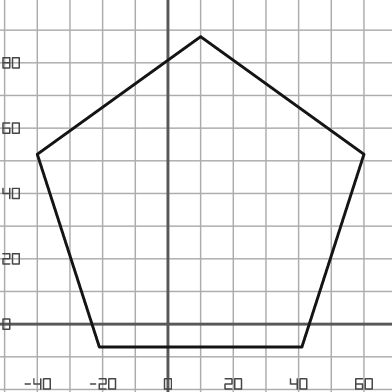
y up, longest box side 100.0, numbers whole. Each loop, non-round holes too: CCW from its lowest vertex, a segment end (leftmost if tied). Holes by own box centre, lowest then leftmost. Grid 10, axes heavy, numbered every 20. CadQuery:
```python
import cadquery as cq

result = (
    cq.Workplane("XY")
    .moveTo(-21.0, -7.0)
    .lineTo(41.0, -7.0)
    .lineTo(60.0, 52.0)
    .lineTo(10.0, 88.0)
    .lineTo(-40.0, 52.0)
    .close()
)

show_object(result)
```